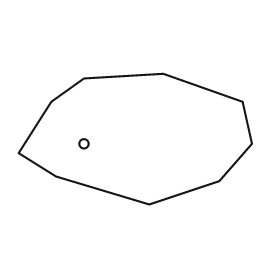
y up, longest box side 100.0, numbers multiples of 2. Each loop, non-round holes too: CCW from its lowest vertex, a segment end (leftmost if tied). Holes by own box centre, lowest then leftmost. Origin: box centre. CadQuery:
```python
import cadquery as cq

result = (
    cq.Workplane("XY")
    .moveTo(6.0, -28.0)
    .lineTo(36.0, -18.0)
    .lineTo(50.0, -2.0)
    .lineTo(46.0, 16.0)
    .lineTo(12.0, 28.0)
    .lineTo(-22.0, 26.0)
    .lineTo(-36.0, 16.0)
    .lineTo(-50.0, -6.0)
    .lineTo(-34.0, -16.0)
    .close()
    .moveTo(-22.0, -2.0)
    .circle(2.0)
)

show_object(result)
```